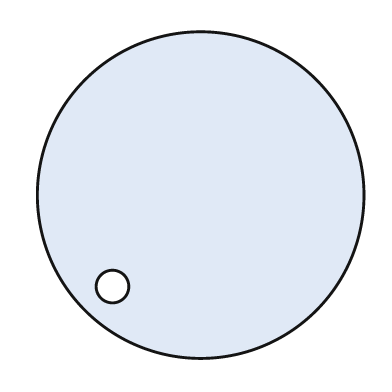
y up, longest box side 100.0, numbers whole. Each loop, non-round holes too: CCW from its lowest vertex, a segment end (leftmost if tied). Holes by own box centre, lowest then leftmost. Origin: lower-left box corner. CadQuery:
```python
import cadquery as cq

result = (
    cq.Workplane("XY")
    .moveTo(50.0, 50.0)
    .circle(50.0)
    .moveTo(23.0, 22.0)
    .circle(5.0)
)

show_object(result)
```